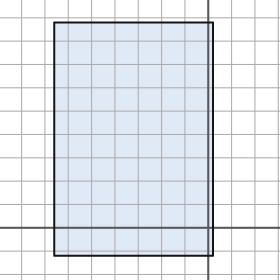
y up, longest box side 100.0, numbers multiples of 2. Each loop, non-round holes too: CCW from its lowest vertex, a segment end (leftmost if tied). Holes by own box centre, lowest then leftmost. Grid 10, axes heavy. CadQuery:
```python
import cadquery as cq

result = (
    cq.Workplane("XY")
    .moveTo(-66.0, -12.0)
    .lineTo(2.0, -12.0)
    .lineTo(2.0, 88.0)
    .lineTo(-66.0, 88.0)
    .close()
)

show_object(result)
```